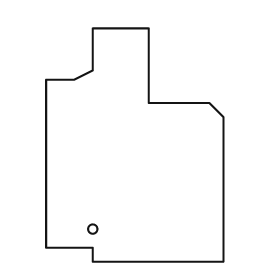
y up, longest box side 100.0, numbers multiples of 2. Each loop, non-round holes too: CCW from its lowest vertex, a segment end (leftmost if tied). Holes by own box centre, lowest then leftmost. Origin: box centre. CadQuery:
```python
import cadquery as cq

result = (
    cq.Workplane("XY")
    .moveTo(-18.0, -50.0)
    .lineTo(38.0, -50.0)
    .lineTo(38.0, 12.0)
    .lineTo(32.0, 18.0)
    .lineTo(6.0, 18.0)
    .lineTo(6.0, 50.0)
    .lineTo(-18.0, 50.0)
    .lineTo(-18.0, 32.0)
    .lineTo(-26.0, 28.0)
    .lineTo(-38.0, 28.0)
    .lineTo(-38.0, -44.0)
    .lineTo(-18.0, -44.0)
    .close()
    .moveTo(-18.0, -36.0)
    .circle(2.0)
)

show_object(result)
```